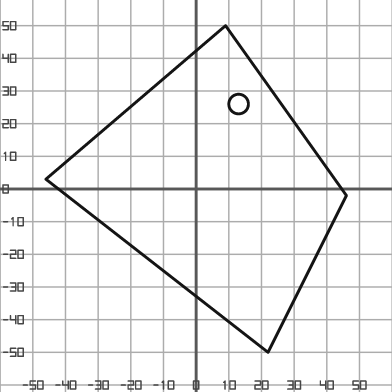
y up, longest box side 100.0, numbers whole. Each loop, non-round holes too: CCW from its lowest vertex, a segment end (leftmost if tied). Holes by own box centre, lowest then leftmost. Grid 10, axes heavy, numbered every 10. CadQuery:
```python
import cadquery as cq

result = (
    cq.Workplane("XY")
    .moveTo(22.0, -50.0)
    .lineTo(46.0, -2.0)
    .lineTo(9.0, 50.0)
    .lineTo(-46.0, 3.0)
    .close()
    .moveTo(13.0, 26.0)
    .circle(3.0)
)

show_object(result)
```